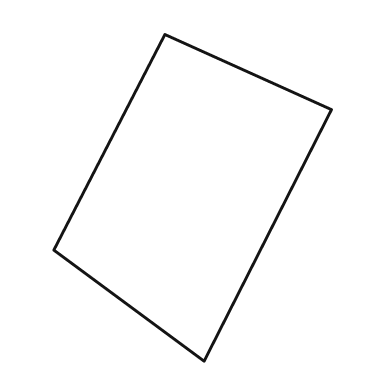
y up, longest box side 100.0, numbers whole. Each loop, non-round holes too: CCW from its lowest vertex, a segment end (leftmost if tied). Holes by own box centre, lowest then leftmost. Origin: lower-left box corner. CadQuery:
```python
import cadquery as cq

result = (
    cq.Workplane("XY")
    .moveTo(46.0, 0.0)
    .lineTo(85.0, 77.0)
    .lineTo(34.0, 100.0)
    .lineTo(0.0, 34.0)
    .close()
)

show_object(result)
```